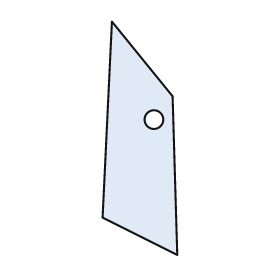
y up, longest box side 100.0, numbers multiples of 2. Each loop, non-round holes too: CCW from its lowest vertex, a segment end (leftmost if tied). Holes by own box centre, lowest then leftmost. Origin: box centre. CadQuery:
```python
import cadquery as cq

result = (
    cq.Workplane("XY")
    .moveTo(16.0, -50.0)
    .lineTo(14.0, 18.0)
    .lineTo(-12.0, 50.0)
    .lineTo(-16.0, -34.0)
    .close()
    .moveTo(6.0, 8.0)
    .circle(4.0)
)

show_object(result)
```